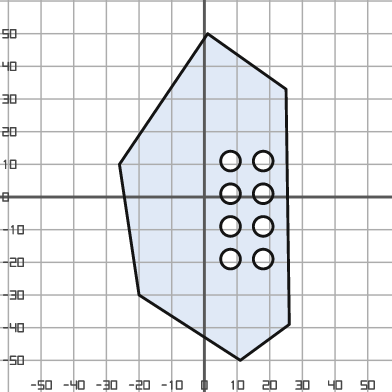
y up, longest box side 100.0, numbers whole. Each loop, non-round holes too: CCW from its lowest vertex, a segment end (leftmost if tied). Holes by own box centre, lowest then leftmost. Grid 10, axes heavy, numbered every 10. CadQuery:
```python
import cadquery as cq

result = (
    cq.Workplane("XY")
    .moveTo(11.0, -50.0)
    .lineTo(26.0, -39.0)
    .lineTo(25.0, 33.0)
    .lineTo(1.0, 50.0)
    .lineTo(-26.0, 10.0)
    .lineTo(-20.0, -30.0)
    .close()
    .moveTo(8.0, -19.0)
    .circle(3.0)
    .moveTo(18.0, -19.0)
    .circle(3.0)
    .moveTo(8.0, -9.0)
    .circle(3.0)
    .moveTo(18.0, -9.0)
    .circle(3.0)
    .moveTo(8.0, 1.0)
    .circle(3.0)
    .moveTo(18.0, 1.0)
    .circle(3.0)
    .moveTo(8.0, 11.0)
    .circle(3.0)
    .moveTo(18.0, 11.0)
    .circle(3.0)
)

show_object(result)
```